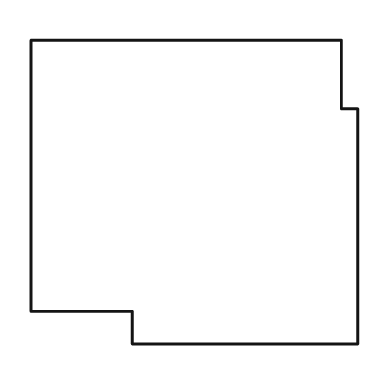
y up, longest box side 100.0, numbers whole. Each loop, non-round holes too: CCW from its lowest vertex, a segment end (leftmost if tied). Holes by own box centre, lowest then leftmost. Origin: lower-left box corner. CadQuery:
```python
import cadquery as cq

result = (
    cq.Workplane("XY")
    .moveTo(31.0, 0.0)
    .lineTo(100.0, 0.0)
    .lineTo(100.0, 72.0)
    .lineTo(95.0, 72.0)
    .lineTo(95.0, 93.0)
    .lineTo(0.0, 93.0)
    .lineTo(0.0, 10.0)
    .lineTo(31.0, 10.0)
    .close()
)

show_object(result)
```